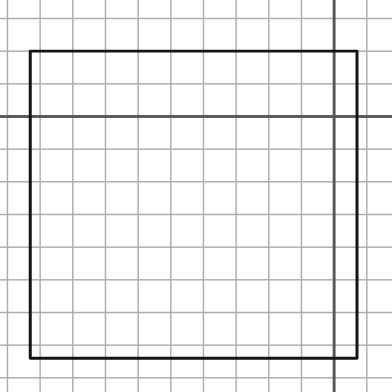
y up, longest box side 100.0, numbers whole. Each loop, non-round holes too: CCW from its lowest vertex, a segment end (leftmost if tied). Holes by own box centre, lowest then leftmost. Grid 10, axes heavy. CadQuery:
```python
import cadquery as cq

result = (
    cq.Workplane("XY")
    .moveTo(-93.0, -74.0)
    .lineTo(7.0, -74.0)
    .lineTo(7.0, 20.0)
    .lineTo(-93.0, 20.0)
    .close()
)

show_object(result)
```